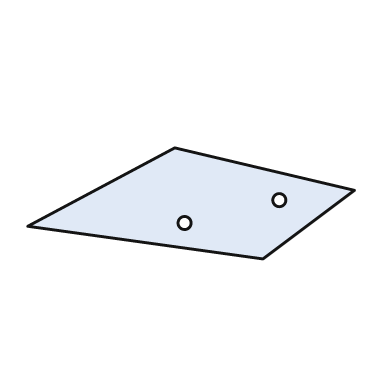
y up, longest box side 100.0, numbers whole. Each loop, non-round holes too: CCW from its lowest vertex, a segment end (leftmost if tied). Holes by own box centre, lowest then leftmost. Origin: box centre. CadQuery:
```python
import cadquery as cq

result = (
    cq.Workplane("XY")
    .moveTo(22.0, -17.0)
    .lineTo(50.0, 4.0)
    .lineTo(-5.0, 17.0)
    .lineTo(-50.0, -7.0)
    .close()
    .moveTo(-2.0, -6.0)
    .circle(2.0)
    .moveTo(27.0, 1.0)
    .circle(2.0)
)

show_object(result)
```